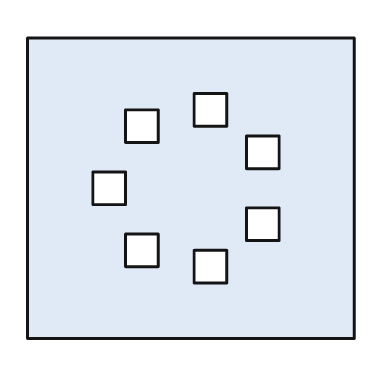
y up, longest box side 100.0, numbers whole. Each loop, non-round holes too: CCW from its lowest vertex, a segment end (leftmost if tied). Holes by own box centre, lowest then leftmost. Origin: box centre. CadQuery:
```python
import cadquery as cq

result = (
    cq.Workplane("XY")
    .moveTo(-50.0, -46.0)
    .lineTo(50.0, -46.0)
    .lineTo(50.0, 46.0)
    .lineTo(-50.0, 46.0)
    .close()
    .moveTo(1.0, -29.0)
    .lineTo(11.0, -29.0)
    .lineTo(11.0, -19.0)
    .lineTo(1.0, -19.0)
    .close()
    .moveTo(-20.0, -24.0)
    .lineTo(-10.0, -24.0)
    .lineTo(-10.0, -14.0)
    .lineTo(-20.0, -14.0)
    .close()
    .moveTo(17.0, -16.0)
    .lineTo(27.0, -16.0)
    .lineTo(27.0, -6.0)
    .lineTo(17.0, -6.0)
    .close()
    .moveTo(-30.0, -5.0)
    .lineTo(-20.0, -5.0)
    .lineTo(-20.0, 5.0)
    .lineTo(-30.0, 5.0)
    .close()
    .moveTo(17.0, 6.0)
    .lineTo(27.0, 6.0)
    .lineTo(27.0, 16.0)
    .lineTo(17.0, 16.0)
    .close()
    .moveTo(-20.0, 14.0)
    .lineTo(-10.0, 14.0)
    .lineTo(-10.0, 24.0)
    .lineTo(-20.0, 24.0)
    .close()
    .moveTo(1.0, 19.0)
    .lineTo(11.0, 19.0)
    .lineTo(11.0, 29.0)
    .lineTo(1.0, 29.0)
    .close()
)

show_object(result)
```